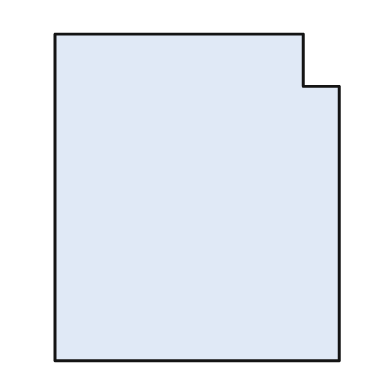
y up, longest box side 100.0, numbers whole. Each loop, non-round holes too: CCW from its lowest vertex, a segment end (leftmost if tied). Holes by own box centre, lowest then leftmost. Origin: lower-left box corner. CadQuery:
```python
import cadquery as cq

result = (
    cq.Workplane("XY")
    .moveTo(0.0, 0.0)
    .lineTo(87.0, 0.0)
    .lineTo(87.0, 84.0)
    .lineTo(76.0, 84.0)
    .lineTo(76.0, 100.0)
    .lineTo(0.0, 100.0)
    .close()
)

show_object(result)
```